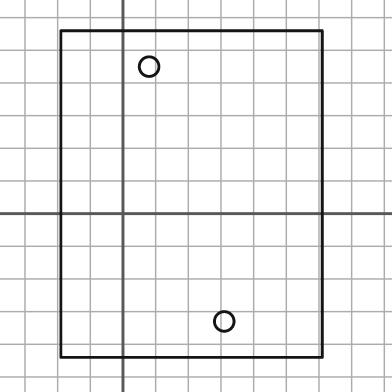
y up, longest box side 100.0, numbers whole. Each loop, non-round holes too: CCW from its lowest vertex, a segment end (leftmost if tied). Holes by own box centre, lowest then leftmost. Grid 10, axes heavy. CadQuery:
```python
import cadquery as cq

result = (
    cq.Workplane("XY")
    .moveTo(-19.0, -44.0)
    .lineTo(61.0, -44.0)
    .lineTo(61.0, 56.0)
    .lineTo(-19.0, 56.0)
    .close()
    .moveTo(31.0, -33.0)
    .circle(3.0)
    .moveTo(8.0, 45.0)
    .circle(3.0)
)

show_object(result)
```